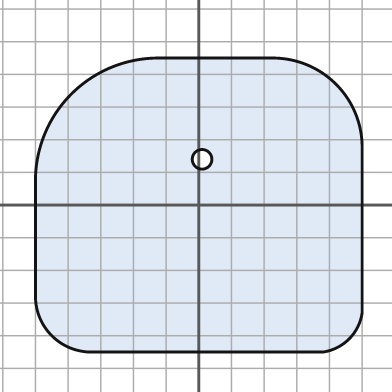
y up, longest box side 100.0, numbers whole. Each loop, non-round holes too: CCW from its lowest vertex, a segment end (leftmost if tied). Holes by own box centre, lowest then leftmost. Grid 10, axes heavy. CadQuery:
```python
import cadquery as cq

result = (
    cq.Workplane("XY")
    .moveTo(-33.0, -45.0)
    .lineTo(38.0, -45.0)
    .threePointArc((46.0, -41.0), (50.0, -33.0))
    .lineTo(50.0, 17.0)
    .threePointArc((42.0, 37.0), (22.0, 45.0))
    .lineTo(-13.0, 45.0)
    .threePointArc((-39.0, 34.0), (-50.0, 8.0))
    .lineTo(-50.0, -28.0)
    .threePointArc((-45.0, -40.0), (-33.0, -45.0))
    .close()
    .moveTo(1.0, 14.0)
    .circle(3.0)
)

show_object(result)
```